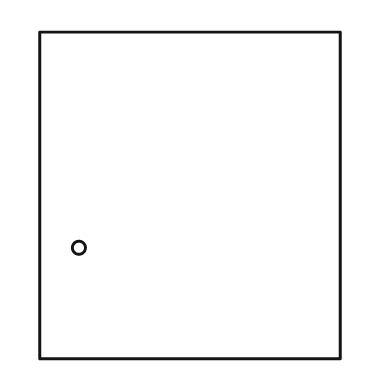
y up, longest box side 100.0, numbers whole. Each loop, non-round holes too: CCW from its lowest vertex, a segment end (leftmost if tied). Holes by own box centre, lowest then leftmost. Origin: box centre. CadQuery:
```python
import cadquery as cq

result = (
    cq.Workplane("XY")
    .moveTo(-46.0, -50.0)
    .lineTo(46.0, -50.0)
    .lineTo(46.0, 50.0)
    .lineTo(-46.0, 50.0)
    .close()
    .moveTo(-34.0, -16.0)
    .circle(2.0)
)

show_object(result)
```